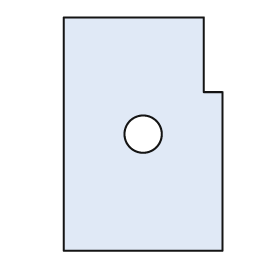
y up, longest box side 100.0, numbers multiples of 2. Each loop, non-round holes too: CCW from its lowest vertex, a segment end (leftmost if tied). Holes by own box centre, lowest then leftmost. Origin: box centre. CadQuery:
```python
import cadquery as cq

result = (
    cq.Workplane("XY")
    .moveTo(-34.0, -50.0)
    .lineTo(34.0, -50.0)
    .lineTo(34.0, 18.0)
    .lineTo(26.0, 18.0)
    .lineTo(26.0, 50.0)
    .lineTo(-34.0, 50.0)
    .close()
    .moveTo(0.0, 0.0)
    .circle(8.0)
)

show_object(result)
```